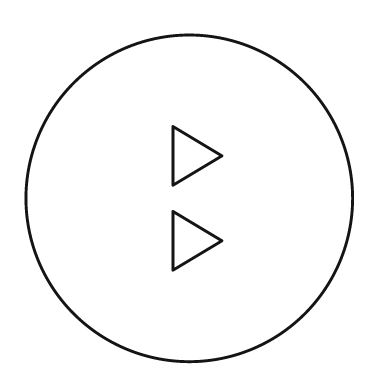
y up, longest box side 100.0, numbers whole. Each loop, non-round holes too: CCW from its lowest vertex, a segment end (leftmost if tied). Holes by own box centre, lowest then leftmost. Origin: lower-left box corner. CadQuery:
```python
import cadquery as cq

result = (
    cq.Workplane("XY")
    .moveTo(50.0, 50.0)
    .circle(50.0)
    .moveTo(45.0, 28.0)
    .lineTo(60.0, 37.0)
    .lineTo(45.0, 46.0)
    .close()
    .moveTo(45.0, 54.0)
    .lineTo(60.0, 63.0)
    .lineTo(45.0, 72.0)
    .close()
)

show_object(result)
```